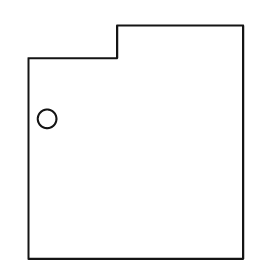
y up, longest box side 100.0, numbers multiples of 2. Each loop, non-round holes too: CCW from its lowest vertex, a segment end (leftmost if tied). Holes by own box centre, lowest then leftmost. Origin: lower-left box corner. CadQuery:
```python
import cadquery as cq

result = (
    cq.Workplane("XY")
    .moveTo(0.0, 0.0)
    .lineTo(92.0, 0.0)
    .lineTo(92.0, 100.0)
    .lineTo(38.0, 100.0)
    .lineTo(38.0, 86.0)
    .lineTo(0.0, 86.0)
    .close()
    .moveTo(8.0, 60.0)
    .circle(4.0)
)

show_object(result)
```